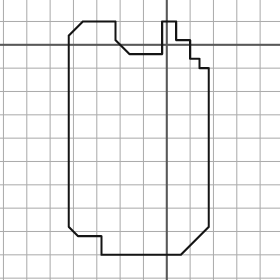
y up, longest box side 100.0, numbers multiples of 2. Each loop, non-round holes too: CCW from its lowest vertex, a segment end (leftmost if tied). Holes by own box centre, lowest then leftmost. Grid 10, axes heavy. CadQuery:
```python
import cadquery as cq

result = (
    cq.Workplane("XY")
    .moveTo(-28.0, -90.0)
    .lineTo(6.0, -90.0)
    .lineTo(18.0, -78.0)
    .lineTo(18.0, -10.0)
    .lineTo(14.0, -10.0)
    .lineTo(14.0, -6.0)
    .lineTo(10.0, -6.0)
    .lineTo(10.0, 2.0)
    .lineTo(4.0, 2.0)
    .lineTo(4.0, 10.0)
    .lineTo(-2.0, 10.0)
    .lineTo(-2.0, -4.0)
    .lineTo(-16.0, -4.0)
    .lineTo(-22.0, 2.0)
    .lineTo(-22.0, 10.0)
    .lineTo(-36.0, 10.0)
    .lineTo(-42.0, 4.0)
    .lineTo(-42.0, -78.0)
    .lineTo(-38.0, -82.0)
    .lineTo(-28.0, -82.0)
    .close()
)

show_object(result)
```